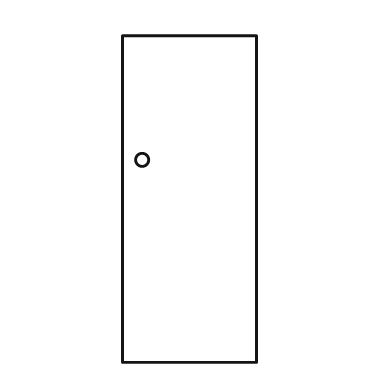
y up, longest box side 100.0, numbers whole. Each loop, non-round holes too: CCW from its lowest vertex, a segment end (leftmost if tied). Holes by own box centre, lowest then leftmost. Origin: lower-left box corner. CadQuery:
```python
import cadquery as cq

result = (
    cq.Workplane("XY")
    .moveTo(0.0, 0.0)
    .lineTo(41.0, 0.0)
    .lineTo(41.0, 100.0)
    .lineTo(0.0, 100.0)
    .close()
    .moveTo(6.0, 62.0)
    .circle(2.0)
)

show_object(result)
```